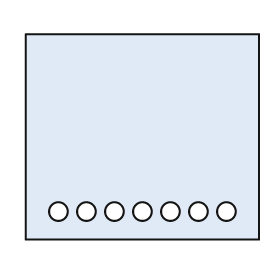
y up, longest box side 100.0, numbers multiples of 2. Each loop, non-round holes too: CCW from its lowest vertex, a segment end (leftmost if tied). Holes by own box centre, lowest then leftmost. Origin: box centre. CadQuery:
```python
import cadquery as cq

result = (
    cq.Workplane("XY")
    .moveTo(-50.0, -44.0)
    .lineTo(50.0, -44.0)
    .lineTo(50.0, 44.0)
    .lineTo(-50.0, 44.0)
    .close()
    .moveTo(-36.0, -32.0)
    .circle(4.0)
    .moveTo(-24.0, -32.0)
    .circle(4.0)
    .moveTo(-12.0, -32.0)
    .circle(4.0)
    .moveTo(0.0, -32.0)
    .circle(4.0)
    .moveTo(12.0, -32.0)
    .circle(4.0)
    .moveTo(24.0, -32.0)
    .circle(4.0)
    .moveTo(36.0, -32.0)
    .circle(4.0)
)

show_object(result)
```